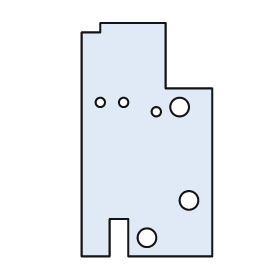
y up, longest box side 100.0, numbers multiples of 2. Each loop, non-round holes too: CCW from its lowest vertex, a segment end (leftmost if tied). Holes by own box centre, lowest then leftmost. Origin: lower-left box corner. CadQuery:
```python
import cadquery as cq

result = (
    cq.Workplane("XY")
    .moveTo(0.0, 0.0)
    .lineTo(12.0, 0.0)
    .lineTo(12.0, 16.0)
    .lineTo(20.0, 16.0)
    .lineTo(20.0, 0.0)
    .lineTo(56.0, 0.0)
    .lineTo(56.0, 72.0)
    .lineTo(36.0, 72.0)
    .lineTo(36.0, 100.0)
    .lineTo(8.0, 100.0)
    .lineTo(8.0, 96.0)
    .lineTo(0.0, 96.0)
    .close()
    .moveTo(28.0, 8.0)
    .circle(4.0)
    .moveTo(46.0, 24.0)
    .circle(4.0)
    .moveTo(32.0, 62.0)
    .circle(2.0)
    .moveTo(42.0, 64.0)
    .circle(4.0)
    .moveTo(8.0, 66.0)
    .circle(2.0)
    .moveTo(18.0, 66.0)
    .circle(2.0)
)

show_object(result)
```